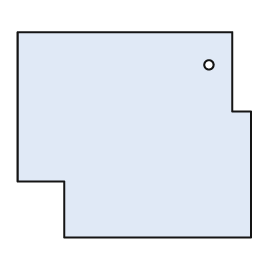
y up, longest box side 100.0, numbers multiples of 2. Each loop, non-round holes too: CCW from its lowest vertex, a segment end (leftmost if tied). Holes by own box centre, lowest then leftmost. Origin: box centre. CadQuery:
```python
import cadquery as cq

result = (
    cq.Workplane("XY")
    .moveTo(-30.0, -44.0)
    .lineTo(50.0, -44.0)
    .lineTo(50.0, 10.0)
    .lineTo(42.0, 10.0)
    .lineTo(42.0, 44.0)
    .lineTo(-50.0, 44.0)
    .lineTo(-50.0, -20.0)
    .lineTo(-30.0, -20.0)
    .close()
    .moveTo(32.0, 30.0)
    .circle(2.0)
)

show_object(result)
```